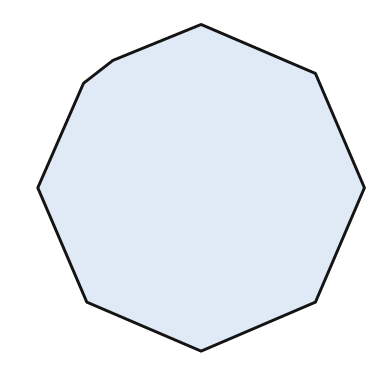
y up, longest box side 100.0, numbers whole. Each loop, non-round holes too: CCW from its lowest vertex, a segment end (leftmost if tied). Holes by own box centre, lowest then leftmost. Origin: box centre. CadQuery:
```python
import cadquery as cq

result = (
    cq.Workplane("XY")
    .moveTo(0.0, -50.0)
    .lineTo(35.0, -35.0)
    .lineTo(50.0, 0.0)
    .lineTo(35.0, 35.0)
    .lineTo(0.0, 50.0)
    .lineTo(-27.0, 39.0)
    .lineTo(-36.0, 32.0)
    .lineTo(-50.0, 0.0)
    .lineTo(-35.0, -35.0)
    .close()
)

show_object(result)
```